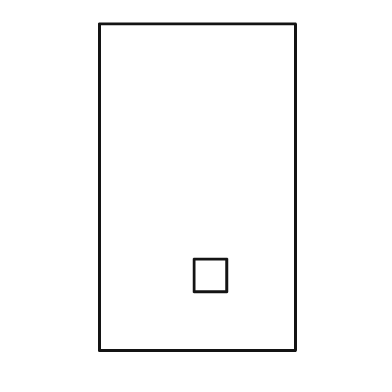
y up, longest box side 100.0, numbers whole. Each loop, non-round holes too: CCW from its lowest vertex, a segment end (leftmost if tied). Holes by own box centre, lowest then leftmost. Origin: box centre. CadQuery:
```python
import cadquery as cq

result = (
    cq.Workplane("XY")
    .moveTo(-30.0, -50.0)
    .lineTo(30.0, -50.0)
    .lineTo(30.0, 50.0)
    .lineTo(-30.0, 50.0)
    .close()
    .moveTo(-1.0, -32.0)
    .lineTo(9.0, -32.0)
    .lineTo(9.0, -22.0)
    .lineTo(-1.0, -22.0)
    .close()
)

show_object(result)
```